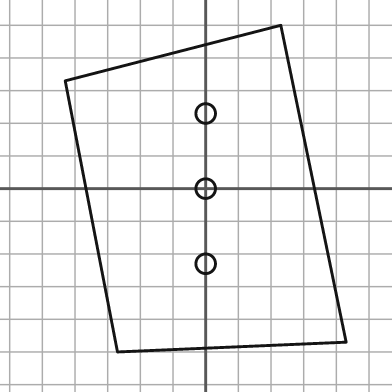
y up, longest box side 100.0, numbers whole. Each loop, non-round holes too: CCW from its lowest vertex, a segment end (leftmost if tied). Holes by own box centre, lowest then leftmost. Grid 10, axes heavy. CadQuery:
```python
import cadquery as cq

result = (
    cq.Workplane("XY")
    .moveTo(-27.0, -50.0)
    .lineTo(43.0, -47.0)
    .lineTo(23.0, 50.0)
    .lineTo(-43.0, 33.0)
    .close()
    .moveTo(0.0, -23.0)
    .circle(3.0)
    .moveTo(0.0, 0.0)
    .circle(3.0)
    .moveTo(0.0, 23.0)
    .circle(3.0)
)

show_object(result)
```